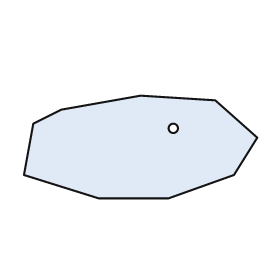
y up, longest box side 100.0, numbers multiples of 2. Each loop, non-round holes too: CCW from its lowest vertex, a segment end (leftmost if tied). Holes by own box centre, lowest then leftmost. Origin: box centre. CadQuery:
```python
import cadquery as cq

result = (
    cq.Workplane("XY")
    .moveTo(-18.0, -22.0)
    .lineTo(12.0, -22.0)
    .lineTo(40.0, -12.0)
    .lineTo(50.0, 4.0)
    .lineTo(32.0, 20.0)
    .lineTo(0.0, 22.0)
    .lineTo(-34.0, 16.0)
    .lineTo(-46.0, 10.0)
    .lineTo(-50.0, -12.0)
    .close()
    .moveTo(14.0, 8.0)
    .circle(2.0)
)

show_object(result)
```